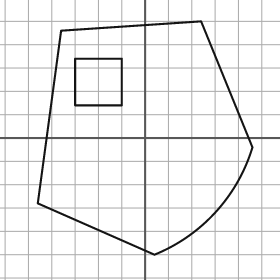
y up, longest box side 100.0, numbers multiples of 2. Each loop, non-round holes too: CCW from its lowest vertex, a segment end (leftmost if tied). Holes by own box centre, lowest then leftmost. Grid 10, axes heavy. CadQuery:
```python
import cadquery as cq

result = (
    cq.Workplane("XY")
    .moveTo(4.0, -50.0)
    .threePointArc((30.0, -32.0), (46.0, -4.0))
    .lineTo(24.0, 50.0)
    .lineTo(-36.0, 46.0)
    .lineTo(-46.0, -28.0)
    .close()
    .moveTo(-30.0, 14.0)
    .lineTo(-10.0, 14.0)
    .lineTo(-10.0, 34.0)
    .lineTo(-30.0, 34.0)
    .close()
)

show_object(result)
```